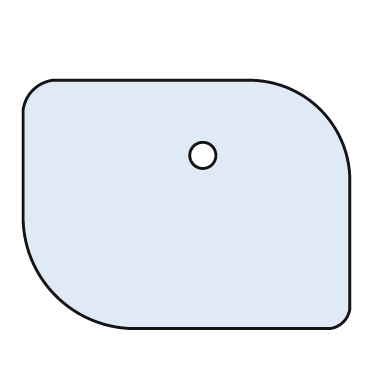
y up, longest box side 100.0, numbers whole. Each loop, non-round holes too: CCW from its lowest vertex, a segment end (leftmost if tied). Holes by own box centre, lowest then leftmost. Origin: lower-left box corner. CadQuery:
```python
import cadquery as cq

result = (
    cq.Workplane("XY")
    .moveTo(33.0, 0.0)
    .lineTo(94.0, 0.0)
    .threePointArc((98.0, 2.0), (100.0, 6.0))
    .lineTo(100.0, 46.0)
    .threePointArc((91.0, 67.0), (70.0, 76.0))
    .lineTo(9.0, 76.0)
    .threePointArc((3.0, 73.0), (0.0, 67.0))
    .lineTo(0.0, 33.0)
    .threePointArc((10.0, 10.0), (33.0, 0.0))
    .close()
    .moveTo(55.0, 53.0)
    .circle(4.0)
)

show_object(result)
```